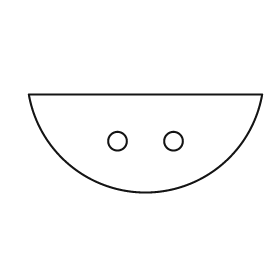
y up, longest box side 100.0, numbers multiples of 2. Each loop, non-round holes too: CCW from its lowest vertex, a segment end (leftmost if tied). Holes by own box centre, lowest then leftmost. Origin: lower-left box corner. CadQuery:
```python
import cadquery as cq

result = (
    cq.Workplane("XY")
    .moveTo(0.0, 42.0)
    .threePointArc((50.0, 0.0), (100.0, 42.0))
    .close()
    .moveTo(38.0, 22.0)
    .circle(4.0)
    .moveTo(62.0, 22.0)
    .circle(4.0)
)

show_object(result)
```